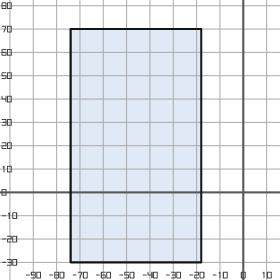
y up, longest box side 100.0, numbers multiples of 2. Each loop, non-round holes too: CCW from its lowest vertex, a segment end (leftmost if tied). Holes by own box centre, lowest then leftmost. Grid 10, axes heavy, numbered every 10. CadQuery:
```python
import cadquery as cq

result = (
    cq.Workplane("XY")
    .moveTo(-74.0, -30.0)
    .lineTo(-18.0, -30.0)
    .lineTo(-18.0, 70.0)
    .lineTo(-74.0, 70.0)
    .close()
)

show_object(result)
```